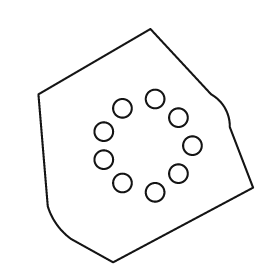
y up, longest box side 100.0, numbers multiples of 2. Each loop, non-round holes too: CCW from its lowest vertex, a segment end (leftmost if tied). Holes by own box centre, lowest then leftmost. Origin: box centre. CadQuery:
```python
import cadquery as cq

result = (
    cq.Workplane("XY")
    .moveTo(-14.0, -50.0)
    .lineTo(46.0, -18.0)
    .lineTo(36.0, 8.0)
    .threePointArc((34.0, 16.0), (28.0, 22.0))
    .lineTo(2.0, 50.0)
    .lineTo(-46.0, 22.0)
    .lineTo(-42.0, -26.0)
    .threePointArc((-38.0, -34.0), (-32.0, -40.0))
    .close()
    .moveTo(4.0, -20.0)
    .circle(4.0)
    .moveTo(-10.0, -16.0)
    .circle(4.0)
    .moveTo(14.0, -12.0)
    .circle(4.0)
    .moveTo(-18.0, -6.0)
    .circle(4.0)
    .moveTo(20.0, 0.0)
    .circle(4.0)
    .moveTo(-18.0, 6.0)
    .circle(4.0)
    .moveTo(14.0, 12.0)
    .circle(4.0)
    .moveTo(-10.0, 16.0)
    .circle(4.0)
    .moveTo(4.0, 20.0)
    .circle(4.0)
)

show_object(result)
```